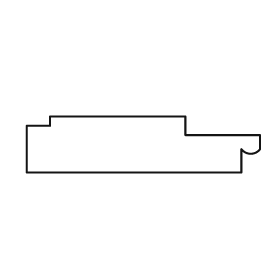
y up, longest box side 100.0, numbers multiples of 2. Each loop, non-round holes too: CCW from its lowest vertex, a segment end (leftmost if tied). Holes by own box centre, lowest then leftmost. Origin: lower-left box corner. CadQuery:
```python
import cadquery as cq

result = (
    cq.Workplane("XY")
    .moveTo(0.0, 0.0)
    .lineTo(92.0, 0.0)
    .lineTo(92.0, 10.0)
    .threePointArc((96.0, 8.0), (100.0, 10.0))
    .lineTo(100.0, 16.0)
    .lineTo(68.0, 16.0)
    .lineTo(68.0, 24.0)
    .lineTo(10.0, 24.0)
    .lineTo(10.0, 20.0)
    .lineTo(0.0, 20.0)
    .close()
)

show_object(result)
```